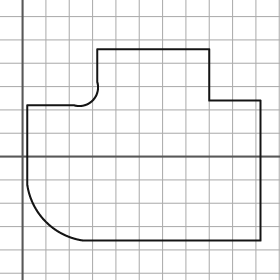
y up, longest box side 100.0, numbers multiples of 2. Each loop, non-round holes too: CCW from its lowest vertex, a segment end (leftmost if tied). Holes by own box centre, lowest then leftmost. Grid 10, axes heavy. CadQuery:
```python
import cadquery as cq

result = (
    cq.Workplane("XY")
    .moveTo(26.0, -36.0)
    .lineTo(102.0, -36.0)
    .lineTo(102.0, 24.0)
    .lineTo(80.0, 24.0)
    .lineTo(80.0, 46.0)
    .lineTo(32.0, 46.0)
    .lineTo(32.0, 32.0)
    .threePointArc((30.0, 24.0), (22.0, 22.0))
    .lineTo(2.0, 22.0)
    .lineTo(2.0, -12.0)
    .threePointArc((10.0, -28.0), (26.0, -36.0))
    .close()
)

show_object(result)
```